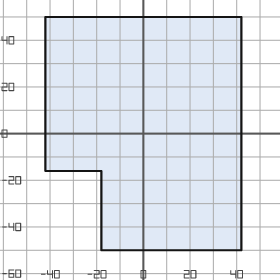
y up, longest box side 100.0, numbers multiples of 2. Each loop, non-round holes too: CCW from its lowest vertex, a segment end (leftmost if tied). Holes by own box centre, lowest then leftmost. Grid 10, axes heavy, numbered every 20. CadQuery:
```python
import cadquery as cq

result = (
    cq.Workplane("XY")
    .moveTo(-18.0, -50.0)
    .lineTo(42.0, -50.0)
    .lineTo(42.0, 50.0)
    .lineTo(-42.0, 50.0)
    .lineTo(-42.0, -16.0)
    .lineTo(-18.0, -16.0)
    .close()
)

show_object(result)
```